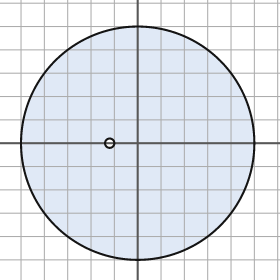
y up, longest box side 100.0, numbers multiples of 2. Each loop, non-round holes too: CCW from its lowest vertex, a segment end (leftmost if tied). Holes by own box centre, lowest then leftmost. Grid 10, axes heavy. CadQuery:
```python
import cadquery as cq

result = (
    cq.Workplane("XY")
    .moveTo(0.0, 0.0)
    .circle(50.0)
    .moveTo(-12.0, 0.0)
    .circle(2.0)
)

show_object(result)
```